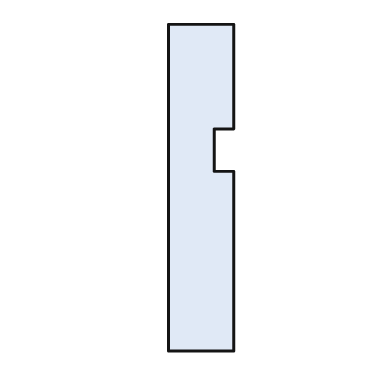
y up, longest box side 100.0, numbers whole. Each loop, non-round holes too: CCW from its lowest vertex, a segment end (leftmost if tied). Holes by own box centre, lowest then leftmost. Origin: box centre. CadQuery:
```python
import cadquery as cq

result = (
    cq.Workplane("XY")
    .moveTo(-10.0, -50.0)
    .lineTo(10.0, -50.0)
    .lineTo(10.0, 5.0)
    .lineTo(4.0, 5.0)
    .lineTo(4.0, 18.0)
    .lineTo(10.0, 18.0)
    .lineTo(10.0, 50.0)
    .lineTo(-10.0, 50.0)
    .close()
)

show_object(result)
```